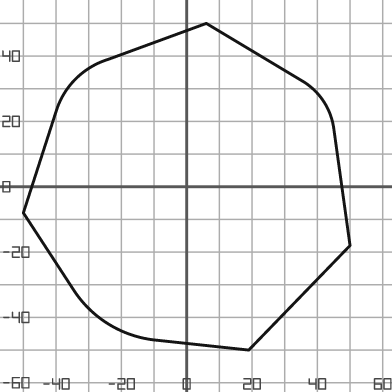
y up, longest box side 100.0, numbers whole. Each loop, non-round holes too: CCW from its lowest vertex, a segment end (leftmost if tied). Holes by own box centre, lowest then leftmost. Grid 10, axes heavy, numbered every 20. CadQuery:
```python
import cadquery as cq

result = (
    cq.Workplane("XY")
    .moveTo(19.0, -50.0)
    .lineTo(50.0, -18.0)
    .lineTo(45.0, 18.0)
    .threePointArc((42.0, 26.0), (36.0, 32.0))
    .lineTo(6.0, 50.0)
    .lineTo(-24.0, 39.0)
    .threePointArc((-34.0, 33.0), (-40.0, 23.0))
    .lineTo(-50.0, -8.0)
    .lineTo(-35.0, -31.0)
    .threePointArc((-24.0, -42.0), (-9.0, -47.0))
    .close()
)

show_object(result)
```